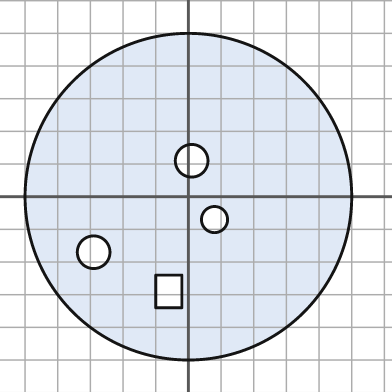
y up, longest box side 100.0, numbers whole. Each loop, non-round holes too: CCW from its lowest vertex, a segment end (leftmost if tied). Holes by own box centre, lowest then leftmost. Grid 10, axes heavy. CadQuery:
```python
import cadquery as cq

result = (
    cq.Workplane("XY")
    .moveTo(0.0, 0.0)
    .circle(50.0)
    .moveTo(-10.0, -34.0)
    .lineTo(-2.0, -34.0)
    .lineTo(-2.0, -24.0)
    .lineTo(-10.0, -24.0)
    .close()
    .moveTo(-29.0, -17.0)
    .circle(5.0)
    .moveTo(8.0, -7.0)
    .circle(4.0)
    .moveTo(1.0, 11.0)
    .circle(5.0)
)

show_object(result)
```